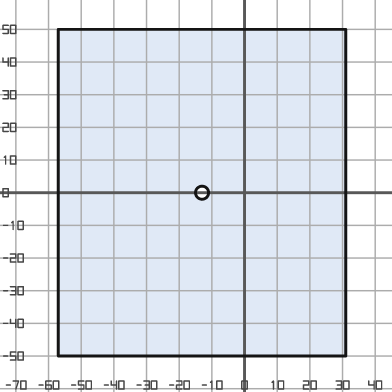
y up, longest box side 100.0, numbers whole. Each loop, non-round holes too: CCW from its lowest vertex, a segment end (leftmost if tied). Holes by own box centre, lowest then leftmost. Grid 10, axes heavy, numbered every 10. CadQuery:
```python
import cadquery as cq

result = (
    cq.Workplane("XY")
    .moveTo(-57.0, -50.0)
    .lineTo(31.0, -50.0)
    .lineTo(31.0, 50.0)
    .lineTo(-57.0, 50.0)
    .close()
    .moveTo(-13.0, 0.0)
    .circle(2.0)
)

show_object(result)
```